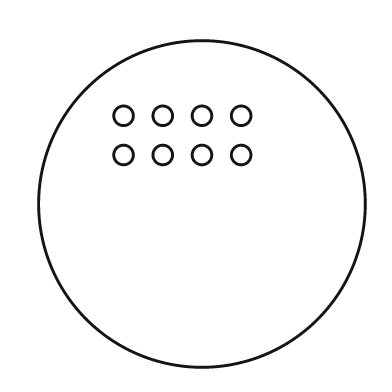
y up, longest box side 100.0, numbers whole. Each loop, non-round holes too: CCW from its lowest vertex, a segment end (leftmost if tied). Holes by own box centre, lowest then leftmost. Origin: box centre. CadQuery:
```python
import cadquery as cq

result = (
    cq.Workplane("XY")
    .moveTo(0.0, 0.0)
    .circle(50.0)
    .moveTo(-24.0, 15.0)
    .circle(3.0)
    .moveTo(-12.0, 15.0)
    .circle(3.0)
    .moveTo(0.0, 15.0)
    .circle(3.0)
    .moveTo(12.0, 15.0)
    .circle(3.0)
    .moveTo(-24.0, 27.0)
    .circle(3.0)
    .moveTo(-12.0, 27.0)
    .circle(3.0)
    .moveTo(0.0, 27.0)
    .circle(3.0)
    .moveTo(12.0, 27.0)
    .circle(3.0)
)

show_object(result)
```